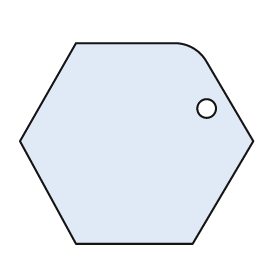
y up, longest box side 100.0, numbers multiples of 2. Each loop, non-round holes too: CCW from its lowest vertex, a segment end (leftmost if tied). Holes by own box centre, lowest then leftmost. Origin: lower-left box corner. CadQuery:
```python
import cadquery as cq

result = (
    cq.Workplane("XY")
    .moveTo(24.0, 0.0)
    .lineTo(74.0, 0.0)
    .lineTo(100.0, 44.0)
    .lineTo(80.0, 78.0)
    .threePointArc((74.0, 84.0), (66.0, 86.0))
    .lineTo(24.0, 86.0)
    .lineTo(0.0, 44.0)
    .close()
    .moveTo(80.0, 58.0)
    .circle(4.0)
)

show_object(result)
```